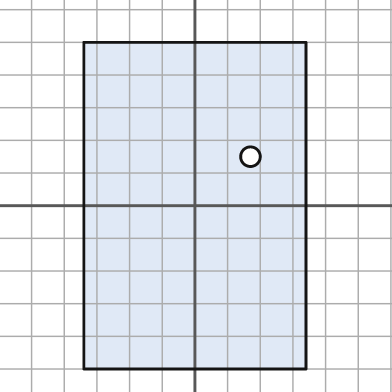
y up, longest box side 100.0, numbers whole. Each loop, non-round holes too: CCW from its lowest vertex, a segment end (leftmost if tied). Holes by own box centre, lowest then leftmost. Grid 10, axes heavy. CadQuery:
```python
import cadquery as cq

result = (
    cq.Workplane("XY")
    .moveTo(-34.0, -50.0)
    .lineTo(34.0, -50.0)
    .lineTo(34.0, 50.0)
    .lineTo(-34.0, 50.0)
    .close()
    .moveTo(17.0, 15.0)
    .circle(3.0)
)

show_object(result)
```